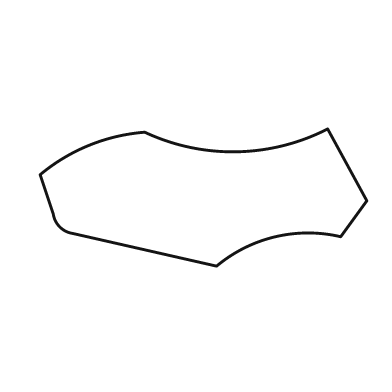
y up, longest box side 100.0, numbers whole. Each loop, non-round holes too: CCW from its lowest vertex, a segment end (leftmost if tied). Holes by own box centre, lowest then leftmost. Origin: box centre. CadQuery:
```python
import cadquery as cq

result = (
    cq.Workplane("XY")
    .moveTo(4.0, -21.0)
    .threePointArc((22.0, -12.0), (42.0, -12.0))
    .lineTo(50.0, -1.0)
    .lineTo(38.0, 21.0)
    .threePointArc((10.0, 14.0), (-18.0, 20.0))
    .threePointArc((-35.0, 16.0), (-50.0, 7.0))
    .lineTo(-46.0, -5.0)
    .threePointArc((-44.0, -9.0), (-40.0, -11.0))
    .close()
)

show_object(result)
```